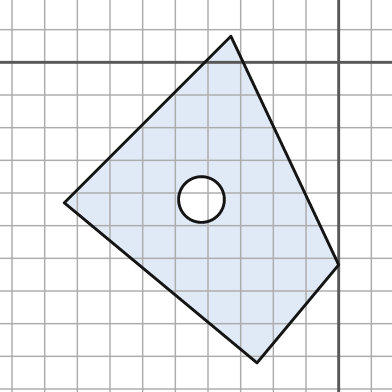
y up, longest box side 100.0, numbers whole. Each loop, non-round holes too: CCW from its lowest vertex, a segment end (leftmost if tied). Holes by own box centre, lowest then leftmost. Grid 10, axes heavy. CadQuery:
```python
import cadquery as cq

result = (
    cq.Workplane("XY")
    .moveTo(-25.0, -92.0)
    .lineTo(0.0, -62.0)
    .lineTo(-33.0, 8.0)
    .lineTo(-84.0, -43.0)
    .close()
    .moveTo(-42.0, -42.0)
    .circle(7.0)
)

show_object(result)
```